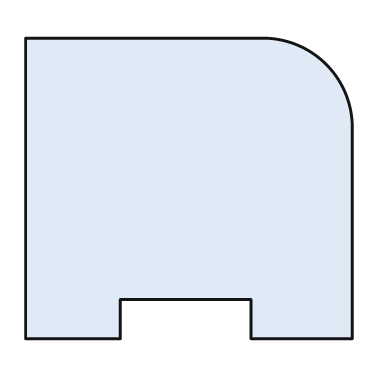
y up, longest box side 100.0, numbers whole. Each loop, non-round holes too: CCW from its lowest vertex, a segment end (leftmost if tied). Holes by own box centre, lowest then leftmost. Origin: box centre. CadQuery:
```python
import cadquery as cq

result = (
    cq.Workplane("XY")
    .moveTo(-50.0, -46.0)
    .lineTo(-21.0, -46.0)
    .lineTo(-21.0, -34.0)
    .lineTo(19.0, -34.0)
    .lineTo(19.0, -46.0)
    .lineTo(50.0, -46.0)
    .lineTo(50.0, 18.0)
    .threePointArc((42.0, 38.0), (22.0, 46.0))
    .lineTo(-50.0, 46.0)
    .close()
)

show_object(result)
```